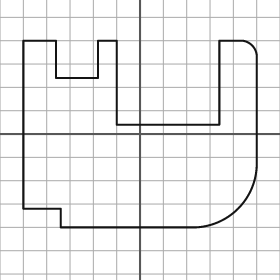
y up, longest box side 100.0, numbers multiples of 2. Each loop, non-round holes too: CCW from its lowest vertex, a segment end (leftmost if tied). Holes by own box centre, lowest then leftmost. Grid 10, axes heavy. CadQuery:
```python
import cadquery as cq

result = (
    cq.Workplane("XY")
    .moveTo(-34.0, -40.0)
    .lineTo(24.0, -40.0)
    .threePointArc((42.0, -32.0), (50.0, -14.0))
    .lineTo(50.0, 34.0)
    .threePointArc((48.0, 38.0), (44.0, 40.0))
    .lineTo(34.0, 40.0)
    .lineTo(34.0, 4.0)
    .lineTo(-10.0, 4.0)
    .lineTo(-10.0, 40.0)
    .lineTo(-18.0, 40.0)
    .lineTo(-18.0, 24.0)
    .lineTo(-36.0, 24.0)
    .lineTo(-36.0, 40.0)
    .lineTo(-50.0, 40.0)
    .lineTo(-50.0, -32.0)
    .lineTo(-34.0, -32.0)
    .close()
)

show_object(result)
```